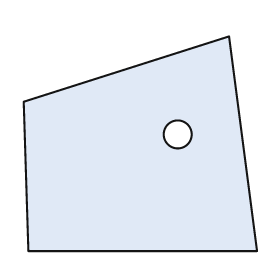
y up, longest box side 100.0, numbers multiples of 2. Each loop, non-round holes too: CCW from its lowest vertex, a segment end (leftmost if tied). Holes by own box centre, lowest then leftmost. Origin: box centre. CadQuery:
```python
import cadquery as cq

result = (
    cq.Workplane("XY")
    .moveTo(-48.0, -46.0)
    .lineTo(50.0, -46.0)
    .lineTo(38.0, 46.0)
    .lineTo(-50.0, 18.0)
    .close()
    .moveTo(16.0, 4.0)
    .circle(6.0)
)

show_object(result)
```